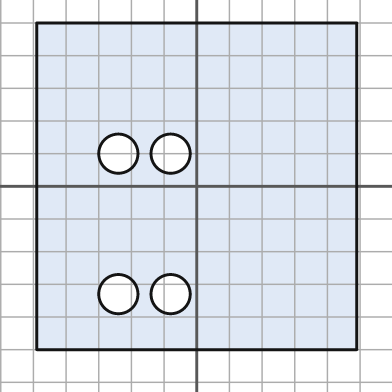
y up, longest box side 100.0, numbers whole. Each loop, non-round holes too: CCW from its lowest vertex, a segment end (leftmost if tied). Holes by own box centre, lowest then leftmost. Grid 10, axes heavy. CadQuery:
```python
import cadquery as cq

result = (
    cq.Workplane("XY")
    .moveTo(-49.0, -50.0)
    .lineTo(49.0, -50.0)
    .lineTo(49.0, 50.0)
    .lineTo(-49.0, 50.0)
    .close()
    .moveTo(-24.0, -33.0)
    .circle(6.0)
    .moveTo(-8.0, -33.0)
    .circle(6.0)
    .moveTo(-24.0, 10.0)
    .circle(6.0)
    .moveTo(-8.0, 10.0)
    .circle(6.0)
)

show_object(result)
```